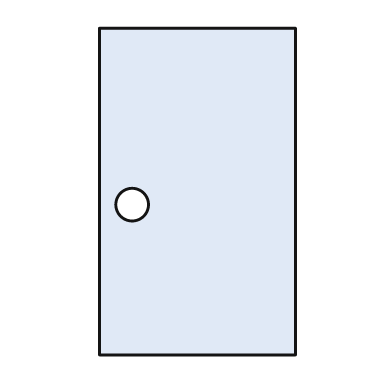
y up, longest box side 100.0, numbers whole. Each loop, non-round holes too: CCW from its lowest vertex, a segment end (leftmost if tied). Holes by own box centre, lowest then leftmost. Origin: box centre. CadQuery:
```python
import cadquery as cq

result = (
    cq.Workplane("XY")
    .moveTo(-30.0, -50.0)
    .lineTo(30.0, -50.0)
    .lineTo(30.0, 50.0)
    .lineTo(-30.0, 50.0)
    .close()
    .moveTo(-20.0, -4.0)
    .circle(5.0)
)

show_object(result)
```